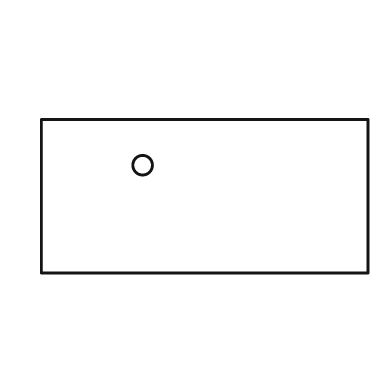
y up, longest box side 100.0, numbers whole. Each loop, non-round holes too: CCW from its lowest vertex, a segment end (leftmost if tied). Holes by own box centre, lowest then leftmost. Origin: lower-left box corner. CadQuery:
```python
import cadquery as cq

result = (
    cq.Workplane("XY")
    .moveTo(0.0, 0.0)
    .lineTo(100.0, 0.0)
    .lineTo(100.0, 47.0)
    .lineTo(0.0, 47.0)
    .close()
    .moveTo(31.0, 33.0)
    .circle(3.0)
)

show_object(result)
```